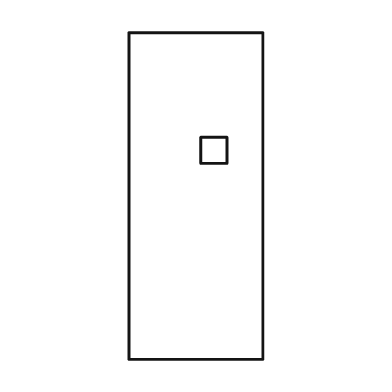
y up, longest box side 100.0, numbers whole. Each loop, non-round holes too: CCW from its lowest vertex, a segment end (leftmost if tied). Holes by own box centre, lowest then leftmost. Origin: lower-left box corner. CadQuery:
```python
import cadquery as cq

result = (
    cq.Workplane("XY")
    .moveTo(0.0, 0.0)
    .lineTo(41.0, 0.0)
    .lineTo(41.0, 100.0)
    .lineTo(0.0, 100.0)
    .close()
    .moveTo(22.0, 60.0)
    .lineTo(30.0, 60.0)
    .lineTo(30.0, 68.0)
    .lineTo(22.0, 68.0)
    .close()
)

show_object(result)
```